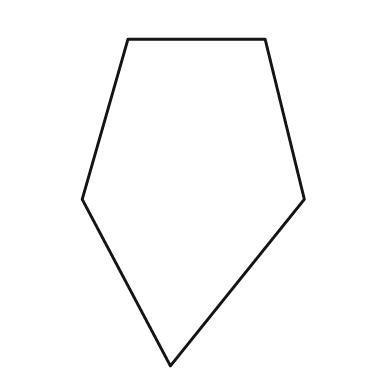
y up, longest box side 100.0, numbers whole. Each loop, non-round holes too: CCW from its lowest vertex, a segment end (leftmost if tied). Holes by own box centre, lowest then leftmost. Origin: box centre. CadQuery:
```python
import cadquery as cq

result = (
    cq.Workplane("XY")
    .moveTo(-7.0, -50.0)
    .lineTo(34.0, 1.0)
    .lineTo(22.0, 50.0)
    .lineTo(-20.0, 50.0)
    .lineTo(-34.0, 1.0)
    .close()
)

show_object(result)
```